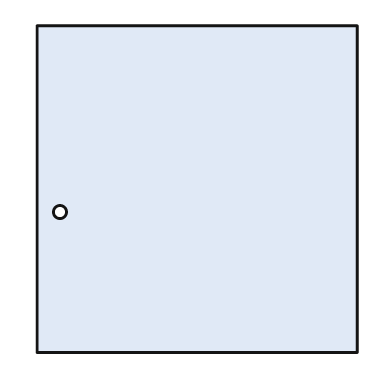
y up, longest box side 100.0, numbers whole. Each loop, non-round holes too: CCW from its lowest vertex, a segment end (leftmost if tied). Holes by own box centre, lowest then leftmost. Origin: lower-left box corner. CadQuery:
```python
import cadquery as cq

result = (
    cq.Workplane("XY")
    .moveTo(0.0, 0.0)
    .lineTo(98.0, 0.0)
    .lineTo(98.0, 100.0)
    .lineTo(0.0, 100.0)
    .close()
    .moveTo(7.0, 43.0)
    .circle(2.0)
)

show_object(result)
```